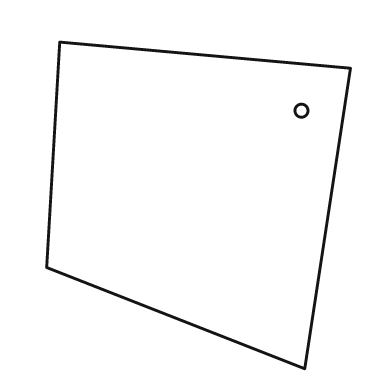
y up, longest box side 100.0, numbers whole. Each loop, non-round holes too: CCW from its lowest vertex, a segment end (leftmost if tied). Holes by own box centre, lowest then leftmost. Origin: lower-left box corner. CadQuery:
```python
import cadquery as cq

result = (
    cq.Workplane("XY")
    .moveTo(79.0, 0.0)
    .lineTo(93.0, 92.0)
    .lineTo(4.0, 100.0)
    .lineTo(0.0, 31.0)
    .close()
    .moveTo(78.0, 79.0)
    .circle(2.0)
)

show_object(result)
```